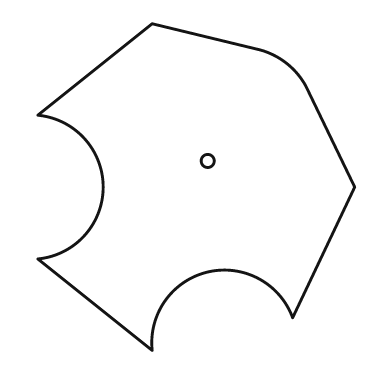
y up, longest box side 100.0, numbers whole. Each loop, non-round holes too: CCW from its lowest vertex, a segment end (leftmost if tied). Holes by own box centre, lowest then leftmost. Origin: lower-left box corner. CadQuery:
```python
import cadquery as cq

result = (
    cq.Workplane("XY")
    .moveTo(35.0, 0.0)
    .threePointArc((52.0, 24.0), (78.0, 10.0))
    .lineTo(97.0, 50.0)
    .lineTo(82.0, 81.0)
    .threePointArc((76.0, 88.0), (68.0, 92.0))
    .lineTo(35.0, 100.0)
    .lineTo(0.0, 72.0)
    .threePointArc((20.0, 50.0), (0.0, 28.0))
    .close()
    .moveTo(52.0, 58.0)
    .circle(2.0)
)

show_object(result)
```